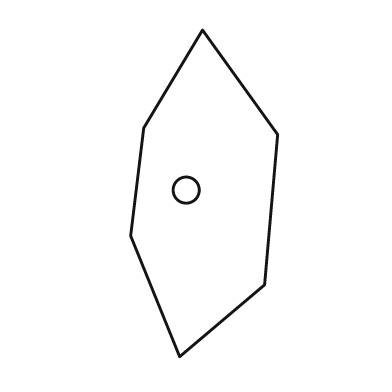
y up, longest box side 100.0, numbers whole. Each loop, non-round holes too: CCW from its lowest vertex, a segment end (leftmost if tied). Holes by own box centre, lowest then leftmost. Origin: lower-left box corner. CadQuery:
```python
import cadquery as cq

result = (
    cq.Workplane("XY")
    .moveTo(15.0, 0.0)
    .lineTo(41.0, 22.0)
    .lineTo(45.0, 68.0)
    .lineTo(22.0, 100.0)
    .lineTo(4.0, 70.0)
    .lineTo(0.0, 37.0)
    .close()
    .moveTo(17.0, 51.0)
    .circle(4.0)
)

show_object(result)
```